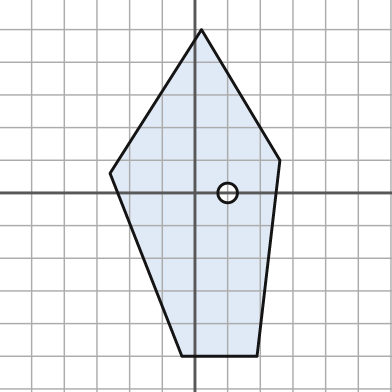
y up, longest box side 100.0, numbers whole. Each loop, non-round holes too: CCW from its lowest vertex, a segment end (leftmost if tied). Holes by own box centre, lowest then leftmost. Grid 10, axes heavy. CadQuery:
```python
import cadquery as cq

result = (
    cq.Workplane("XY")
    .moveTo(-4.0, -50.0)
    .lineTo(19.0, -50.0)
    .lineTo(26.0, 10.0)
    .lineTo(2.0, 50.0)
    .lineTo(-26.0, 6.0)
    .close()
    .moveTo(10.0, 0.0)
    .circle(3.0)
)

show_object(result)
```